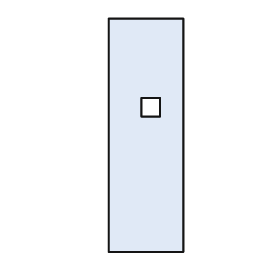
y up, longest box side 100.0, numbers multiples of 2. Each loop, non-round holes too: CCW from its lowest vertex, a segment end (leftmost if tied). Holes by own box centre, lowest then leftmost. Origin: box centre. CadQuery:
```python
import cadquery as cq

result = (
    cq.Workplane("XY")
    .moveTo(-16.0, -50.0)
    .lineTo(16.0, -50.0)
    .lineTo(16.0, 50.0)
    .lineTo(-16.0, 50.0)
    .close()
    .moveTo(-2.0, 8.0)
    .lineTo(6.0, 8.0)
    .lineTo(6.0, 16.0)
    .lineTo(-2.0, 16.0)
    .close()
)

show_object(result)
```